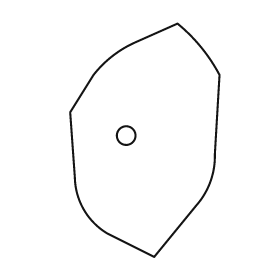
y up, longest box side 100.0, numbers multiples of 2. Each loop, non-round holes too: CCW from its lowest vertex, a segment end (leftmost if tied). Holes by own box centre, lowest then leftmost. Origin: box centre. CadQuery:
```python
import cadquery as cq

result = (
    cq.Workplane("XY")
    .moveTo(4.0, -50.0)
    .lineTo(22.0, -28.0)
    .threePointArc((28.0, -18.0), (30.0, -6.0))
    .lineTo(32.0, 28.0)
    .threePointArc((24.0, 40.0), (14.0, 50.0))
    .lineTo(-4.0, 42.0)
    .threePointArc((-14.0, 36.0), (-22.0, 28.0))
    .lineTo(-32.0, 12.0)
    .lineTo(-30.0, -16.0)
    .threePointArc((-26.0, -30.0), (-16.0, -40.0))
    .close()
    .moveTo(-8.0, 2.0)
    .circle(4.0)
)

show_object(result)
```